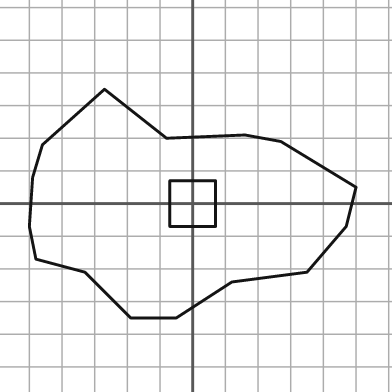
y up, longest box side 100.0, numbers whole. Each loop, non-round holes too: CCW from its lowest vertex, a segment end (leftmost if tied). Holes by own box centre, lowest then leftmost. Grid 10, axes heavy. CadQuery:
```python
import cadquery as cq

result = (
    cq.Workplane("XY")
    .moveTo(-19.0, -35.0)
    .lineTo(-5.0, -35.0)
    .lineTo(12.0, -24.0)
    .lineTo(35.0, -21.0)
    .lineTo(47.0, -7.0)
    .lineTo(50.0, 5.0)
    .lineTo(27.0, 19.0)
    .lineTo(16.0, 21.0)
    .lineTo(-8.0, 20.0)
    .lineTo(-27.0, 35.0)
    .lineTo(-46.0, 18.0)
    .lineTo(-49.0, 8.0)
    .lineTo(-50.0, -7.0)
    .lineTo(-48.0, -17.0)
    .lineTo(-33.0, -21.0)
    .close()
    .moveTo(-7.0, -7.0)
    .lineTo(7.0, -7.0)
    .lineTo(7.0, 7.0)
    .lineTo(-7.0, 7.0)
    .close()
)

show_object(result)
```